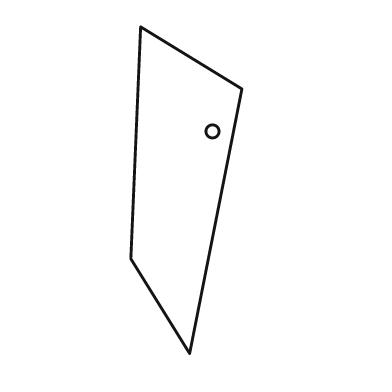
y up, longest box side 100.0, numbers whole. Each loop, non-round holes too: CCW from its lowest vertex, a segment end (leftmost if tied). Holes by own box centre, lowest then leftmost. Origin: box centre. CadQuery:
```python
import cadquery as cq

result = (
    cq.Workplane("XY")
    .moveTo(1.0, -50.0)
    .lineTo(17.0, 31.0)
    .lineTo(-14.0, 50.0)
    .lineTo(-17.0, -21.0)
    .close()
    .moveTo(8.0, 18.0)
    .circle(2.0)
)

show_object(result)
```